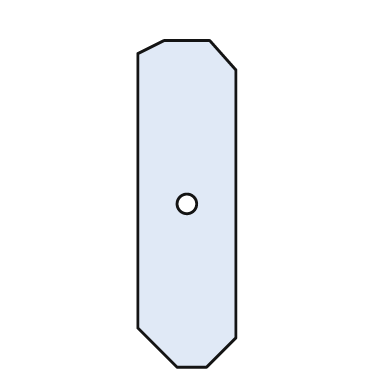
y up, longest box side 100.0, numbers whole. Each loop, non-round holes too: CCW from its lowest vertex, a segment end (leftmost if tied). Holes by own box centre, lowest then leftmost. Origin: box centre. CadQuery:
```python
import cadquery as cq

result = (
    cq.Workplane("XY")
    .moveTo(-3.0, -50.0)
    .lineTo(6.0, -50.0)
    .lineTo(15.0, -41.0)
    .lineTo(15.0, 41.0)
    .lineTo(7.0, 50.0)
    .lineTo(-7.0, 50.0)
    .lineTo(-15.0, 46.0)
    .lineTo(-15.0, -38.0)
    .close()
    .moveTo(0.0, 0.0)
    .circle(3.0)
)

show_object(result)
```